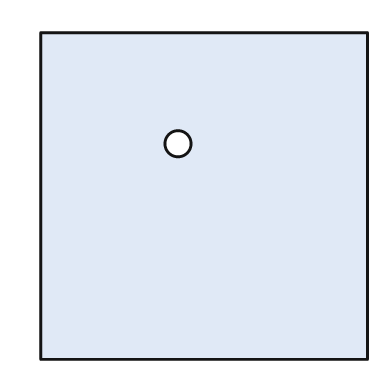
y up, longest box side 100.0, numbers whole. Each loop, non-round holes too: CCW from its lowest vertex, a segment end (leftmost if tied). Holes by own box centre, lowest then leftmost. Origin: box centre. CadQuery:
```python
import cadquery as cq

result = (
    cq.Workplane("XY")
    .moveTo(-50.0, -50.0)
    .lineTo(50.0, -50.0)
    .lineTo(50.0, 50.0)
    .lineTo(-50.0, 50.0)
    .close()
    .moveTo(-8.0, 16.0)
    .circle(4.0)
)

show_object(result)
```